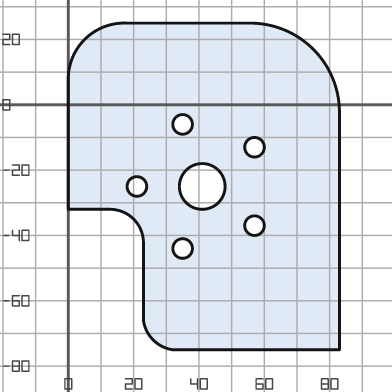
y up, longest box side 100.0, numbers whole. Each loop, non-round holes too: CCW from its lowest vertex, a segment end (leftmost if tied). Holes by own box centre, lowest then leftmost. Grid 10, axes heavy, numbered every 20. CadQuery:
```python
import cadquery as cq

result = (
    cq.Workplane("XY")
    .moveTo(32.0, -75.0)
    .lineTo(83.0, -75.0)
    .lineTo(83.0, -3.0)
    .threePointArc((75.0, 17.0), (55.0, 25.0))
    .lineTo(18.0, 25.0)
    .threePointArc((5.0, 20.0), (0.0, 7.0))
    .lineTo(0.0, -32.0)
    .lineTo(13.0, -32.0)
    .threePointArc((20.0, -35.0), (23.0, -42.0))
    .lineTo(23.0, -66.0)
    .threePointArc((26.0, -72.0), (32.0, -75.0))
    .close()
    .moveTo(35.0, -44.0)
    .circle(3.0)
    .moveTo(57.0, -37.0)
    .circle(3.0)
    .moveTo(21.0, -25.0)
    .circle(3.0)
    .moveTo(41.0, -25.0)
    .circle(7.0)
    .moveTo(57.0, -13.0)
    .circle(3.0)
    .moveTo(35.0, -6.0)
    .circle(3.0)
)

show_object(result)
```